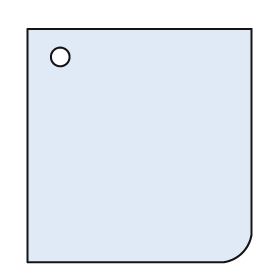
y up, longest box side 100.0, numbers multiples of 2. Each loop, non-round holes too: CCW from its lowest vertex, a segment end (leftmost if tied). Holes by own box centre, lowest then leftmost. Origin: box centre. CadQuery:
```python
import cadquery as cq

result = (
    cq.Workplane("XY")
    .moveTo(-48.0, -50.0)
    .lineTo(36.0, -50.0)
    .threePointArc((44.0, -46.0), (48.0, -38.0))
    .lineTo(48.0, 50.0)
    .lineTo(-48.0, 50.0)
    .close()
    .moveTo(-34.0, 38.0)
    .circle(4.0)
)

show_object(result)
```